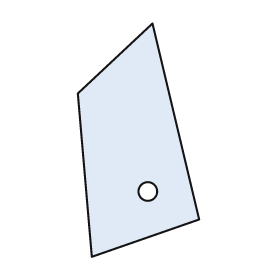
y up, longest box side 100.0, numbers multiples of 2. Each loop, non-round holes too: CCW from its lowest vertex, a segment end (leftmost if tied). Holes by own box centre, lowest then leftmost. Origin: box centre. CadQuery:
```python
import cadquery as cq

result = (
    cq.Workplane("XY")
    .moveTo(-20.0, -50.0)
    .lineTo(26.0, -34.0)
    .lineTo(6.0, 50.0)
    .lineTo(-26.0, 20.0)
    .close()
    .moveTo(4.0, -22.0)
    .circle(4.0)
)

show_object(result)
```